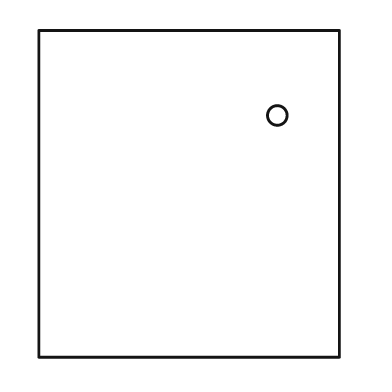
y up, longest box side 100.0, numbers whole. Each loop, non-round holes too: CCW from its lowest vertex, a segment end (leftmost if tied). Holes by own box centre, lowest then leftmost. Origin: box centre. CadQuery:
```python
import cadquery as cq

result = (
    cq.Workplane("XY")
    .moveTo(-46.0, -50.0)
    .lineTo(46.0, -50.0)
    .lineTo(46.0, 50.0)
    .lineTo(-46.0, 50.0)
    .close()
    .moveTo(27.0, 24.0)
    .circle(3.0)
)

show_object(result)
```